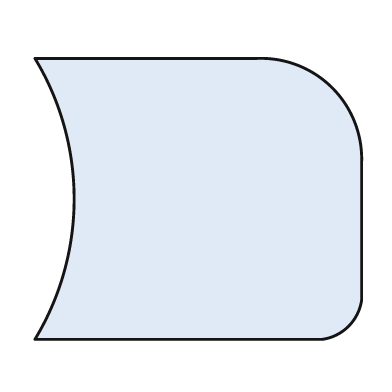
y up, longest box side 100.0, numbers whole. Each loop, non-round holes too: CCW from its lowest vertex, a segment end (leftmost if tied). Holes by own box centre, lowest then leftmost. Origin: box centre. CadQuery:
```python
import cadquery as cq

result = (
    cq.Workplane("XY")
    .moveTo(-50.0, -43.0)
    .lineTo(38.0, -43.0)
    .threePointArc((46.0, -39.0), (50.0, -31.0))
    .lineTo(50.0, 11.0)
    .threePointArc((41.0, 34.0), (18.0, 43.0))
    .lineTo(-50.0, 43.0)
    .threePointArc((-38.0, 0.0), (-50.0, -43.0))
    .close()
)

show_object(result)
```